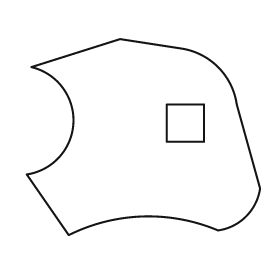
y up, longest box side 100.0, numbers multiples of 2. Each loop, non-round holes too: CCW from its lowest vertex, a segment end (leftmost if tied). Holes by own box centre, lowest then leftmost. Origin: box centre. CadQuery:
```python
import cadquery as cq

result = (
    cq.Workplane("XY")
    .moveTo(-32.0, -42.0)
    .threePointArc((0.0, -34.0), (32.0, -40.0))
    .threePointArc((44.0, -34.0), (50.0, -22.0))
    .lineTo(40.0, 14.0)
    .threePointArc((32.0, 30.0), (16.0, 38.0))
    .lineTo(-10.0, 42.0)
    .lineTo(-48.0, 30.0)
    .threePointArc((-30.0, 6.0), (-50.0, -16.0))
    .close()
    .moveTo(10.0, -2.0)
    .lineTo(26.0, -2.0)
    .lineTo(26.0, 14.0)
    .lineTo(10.0, 14.0)
    .close()
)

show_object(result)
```